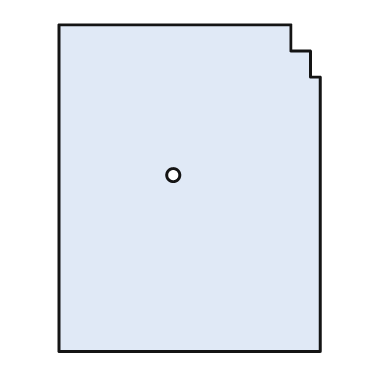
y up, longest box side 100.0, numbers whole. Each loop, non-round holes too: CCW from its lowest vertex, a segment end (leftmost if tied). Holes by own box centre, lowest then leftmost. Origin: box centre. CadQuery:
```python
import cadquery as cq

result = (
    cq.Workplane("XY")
    .moveTo(-40.0, -50.0)
    .lineTo(40.0, -50.0)
    .lineTo(40.0, 34.0)
    .lineTo(37.0, 34.0)
    .lineTo(37.0, 42.0)
    .lineTo(31.0, 42.0)
    .lineTo(31.0, 50.0)
    .lineTo(-40.0, 50.0)
    .close()
    .moveTo(-5.0, 4.0)
    .circle(2.0)
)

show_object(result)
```